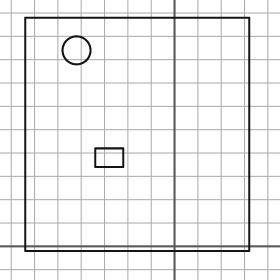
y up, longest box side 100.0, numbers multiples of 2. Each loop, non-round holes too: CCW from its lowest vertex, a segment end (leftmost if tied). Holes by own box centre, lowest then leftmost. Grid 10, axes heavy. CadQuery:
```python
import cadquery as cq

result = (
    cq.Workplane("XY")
    .moveTo(-64.0, -2.0)
    .lineTo(32.0, -2.0)
    .lineTo(32.0, 98.0)
    .lineTo(-64.0, 98.0)
    .close()
    .moveTo(-34.0, 34.0)
    .lineTo(-22.0, 34.0)
    .lineTo(-22.0, 42.0)
    .lineTo(-34.0, 42.0)
    .close()
    .moveTo(-42.0, 84.0)
    .circle(6.0)
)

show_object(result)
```